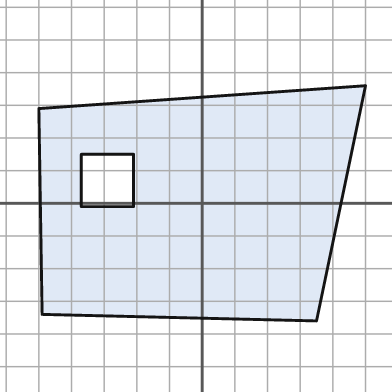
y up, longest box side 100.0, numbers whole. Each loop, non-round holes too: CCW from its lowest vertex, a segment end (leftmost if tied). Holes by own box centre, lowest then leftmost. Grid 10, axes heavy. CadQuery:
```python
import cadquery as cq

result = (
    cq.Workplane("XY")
    .moveTo(35.0, -36.0)
    .lineTo(50.0, 36.0)
    .lineTo(-50.0, 29.0)
    .lineTo(-49.0, -34.0)
    .close()
    .moveTo(-37.0, -1.0)
    .lineTo(-21.0, -1.0)
    .lineTo(-21.0, 15.0)
    .lineTo(-37.0, 15.0)
    .close()
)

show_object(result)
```